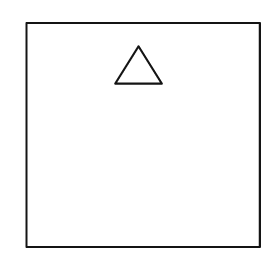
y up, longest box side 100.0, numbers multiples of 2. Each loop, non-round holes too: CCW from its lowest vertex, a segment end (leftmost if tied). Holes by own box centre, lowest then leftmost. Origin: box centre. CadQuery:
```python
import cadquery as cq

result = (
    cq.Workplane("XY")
    .moveTo(-50.0, -48.0)
    .lineTo(50.0, -48.0)
    .lineTo(50.0, 48.0)
    .lineTo(-50.0, 48.0)
    .close()
    .moveTo(-12.0, 22.0)
    .lineTo(8.0, 22.0)
    .lineTo(-2.0, 38.0)
    .close()
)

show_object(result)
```